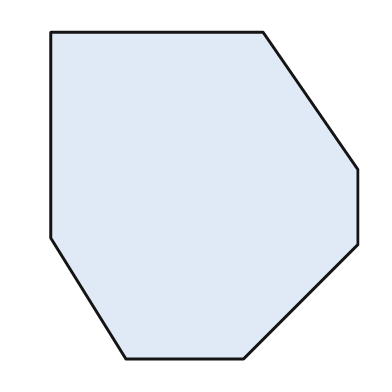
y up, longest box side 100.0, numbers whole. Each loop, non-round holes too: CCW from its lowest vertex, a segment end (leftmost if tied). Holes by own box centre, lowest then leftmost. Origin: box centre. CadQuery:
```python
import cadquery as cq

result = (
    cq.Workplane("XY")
    .moveTo(-24.0, -50.0)
    .lineTo(12.0, -50.0)
    .lineTo(47.0, -15.0)
    .lineTo(47.0, 8.0)
    .lineTo(18.0, 50.0)
    .lineTo(-47.0, 50.0)
    .lineTo(-47.0, -13.0)
    .close()
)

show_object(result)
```